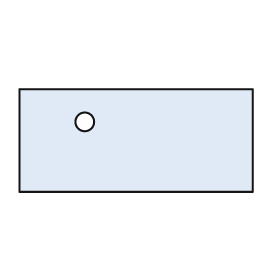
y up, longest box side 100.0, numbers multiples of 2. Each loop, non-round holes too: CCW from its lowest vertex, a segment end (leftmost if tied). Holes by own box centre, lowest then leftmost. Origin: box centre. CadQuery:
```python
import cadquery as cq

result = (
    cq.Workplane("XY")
    .moveTo(-50.0, -22.0)
    .lineTo(50.0, -22.0)
    .lineTo(50.0, 22.0)
    .lineTo(-50.0, 22.0)
    .close()
    .moveTo(-22.0, 8.0)
    .circle(4.0)
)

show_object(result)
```